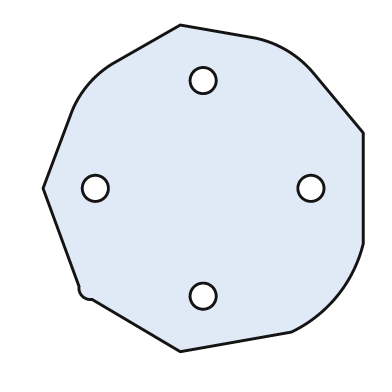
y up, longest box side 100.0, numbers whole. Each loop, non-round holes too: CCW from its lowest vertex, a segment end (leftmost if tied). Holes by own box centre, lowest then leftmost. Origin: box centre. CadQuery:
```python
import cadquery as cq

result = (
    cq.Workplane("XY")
    .moveTo(-7.0, -50.0)
    .lineTo(27.0, -44.0)
    .threePointArc((41.0, -33.0), (49.0, -17.0))
    .lineTo(49.0, 17.0)
    .lineTo(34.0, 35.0)
    .threePointArc((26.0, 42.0), (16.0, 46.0))
    .lineTo(-7.0, 50.0)
    .lineTo(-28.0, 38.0)
    .threePointArc((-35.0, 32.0), (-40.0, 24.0))
    .lineTo(-49.0, 0.0)
    .lineTo(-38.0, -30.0)
    .threePointArc((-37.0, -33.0), (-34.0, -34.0))
    .close()
    .moveTo(0.0, -33.0)
    .circle(4.0)
    .moveTo(-33.0, 0.0)
    .circle(4.0)
    .moveTo(33.0, 0.0)
    .circle(4.0)
    .moveTo(0.0, 33.0)
    .circle(4.0)
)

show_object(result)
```